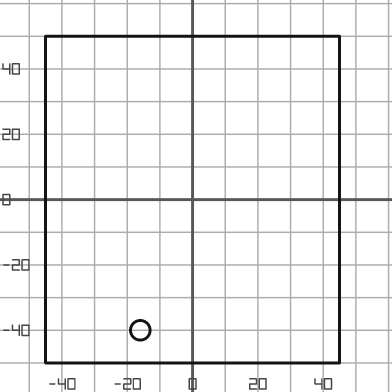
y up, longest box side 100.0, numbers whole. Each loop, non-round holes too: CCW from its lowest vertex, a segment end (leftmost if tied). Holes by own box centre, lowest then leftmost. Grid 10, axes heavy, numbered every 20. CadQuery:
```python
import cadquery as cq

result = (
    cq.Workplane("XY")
    .moveTo(-45.0, -50.0)
    .lineTo(45.0, -50.0)
    .lineTo(45.0, 50.0)
    .lineTo(-45.0, 50.0)
    .close()
    .moveTo(-16.0, -40.0)
    .circle(3.0)
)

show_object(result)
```